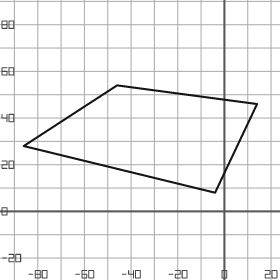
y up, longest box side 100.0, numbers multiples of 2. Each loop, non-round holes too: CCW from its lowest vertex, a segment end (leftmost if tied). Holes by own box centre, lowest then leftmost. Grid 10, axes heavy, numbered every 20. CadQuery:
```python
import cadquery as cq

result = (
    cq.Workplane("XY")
    .moveTo(-4.0, 8.0)
    .lineTo(14.0, 46.0)
    .lineTo(-46.0, 54.0)
    .lineTo(-86.0, 28.0)
    .close()
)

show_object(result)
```